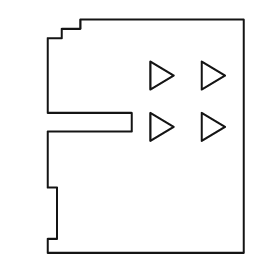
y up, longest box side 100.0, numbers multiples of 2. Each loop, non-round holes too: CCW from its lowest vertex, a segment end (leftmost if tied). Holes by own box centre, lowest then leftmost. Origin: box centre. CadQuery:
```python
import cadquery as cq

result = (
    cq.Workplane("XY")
    .moveTo(-42.0, -50.0)
    .lineTo(42.0, -50.0)
    .lineTo(42.0, 50.0)
    .lineTo(-28.0, 50.0)
    .lineTo(-28.0, 46.0)
    .lineTo(-36.0, 46.0)
    .lineTo(-36.0, 42.0)
    .lineTo(-42.0, 42.0)
    .lineTo(-42.0, 10.0)
    .lineTo(-6.0, 10.0)
    .lineTo(-6.0, 2.0)
    .lineTo(-42.0, 2.0)
    .lineTo(-42.0, -22.0)
    .lineTo(-38.0, -22.0)
    .lineTo(-38.0, -44.0)
    .lineTo(-42.0, -44.0)
    .close()
    .moveTo(2.0, -2.0)
    .lineTo(12.0, 4.0)
    .lineTo(2.0, 10.0)
    .close()
    .moveTo(24.0, -2.0)
    .lineTo(34.0, 4.0)
    .lineTo(24.0, 10.0)
    .close()
    .moveTo(2.0, 20.0)
    .lineTo(12.0, 26.0)
    .lineTo(2.0, 32.0)
    .close()
    .moveTo(24.0, 20.0)
    .lineTo(34.0, 26.0)
    .lineTo(24.0, 32.0)
    .close()
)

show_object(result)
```